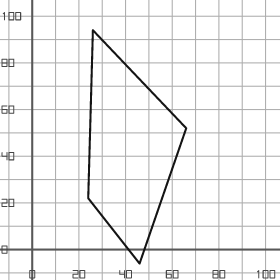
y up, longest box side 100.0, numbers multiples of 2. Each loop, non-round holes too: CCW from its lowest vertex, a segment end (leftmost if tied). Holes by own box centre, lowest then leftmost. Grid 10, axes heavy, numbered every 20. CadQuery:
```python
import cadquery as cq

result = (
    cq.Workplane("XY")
    .moveTo(46.0, -6.0)
    .lineTo(66.0, 52.0)
    .lineTo(26.0, 94.0)
    .lineTo(24.0, 22.0)
    .close()
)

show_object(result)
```